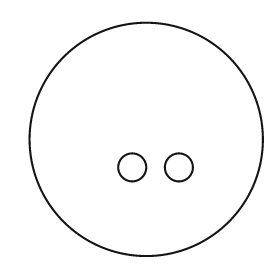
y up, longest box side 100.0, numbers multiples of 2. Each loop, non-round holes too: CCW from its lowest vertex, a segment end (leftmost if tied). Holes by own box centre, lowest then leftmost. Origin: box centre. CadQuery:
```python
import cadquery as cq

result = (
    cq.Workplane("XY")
    .moveTo(0.0, 0.0)
    .circle(50.0)
    .moveTo(-6.0, -12.0)
    .circle(6.0)
    .moveTo(14.0, -12.0)
    .circle(6.0)
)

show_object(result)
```